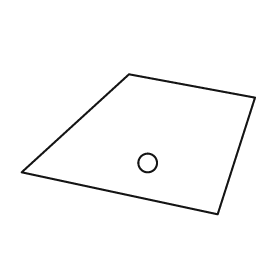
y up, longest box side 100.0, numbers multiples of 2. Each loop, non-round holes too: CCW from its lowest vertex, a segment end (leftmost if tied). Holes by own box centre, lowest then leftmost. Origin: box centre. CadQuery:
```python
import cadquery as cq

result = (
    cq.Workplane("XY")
    .moveTo(34.0, -30.0)
    .lineTo(50.0, 20.0)
    .lineTo(-4.0, 30.0)
    .lineTo(-50.0, -12.0)
    .close()
    .moveTo(4.0, -8.0)
    .circle(4.0)
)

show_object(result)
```